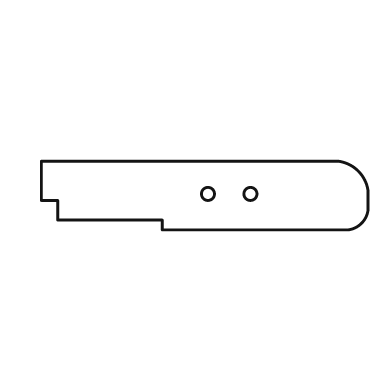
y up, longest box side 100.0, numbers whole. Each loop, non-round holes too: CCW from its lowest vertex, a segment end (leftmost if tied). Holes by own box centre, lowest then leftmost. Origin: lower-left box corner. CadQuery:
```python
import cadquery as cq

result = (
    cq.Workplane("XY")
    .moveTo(37.0, 0.0)
    .lineTo(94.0, 0.0)
    .threePointArc((98.0, 2.0), (100.0, 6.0))
    .lineTo(100.0, 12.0)
    .threePointArc((97.0, 18.0), (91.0, 21.0))
    .lineTo(0.0, 21.0)
    .lineTo(0.0, 9.0)
    .lineTo(5.0, 9.0)
    .lineTo(5.0, 3.0)
    .lineTo(37.0, 3.0)
    .close()
    .moveTo(51.0, 11.0)
    .circle(2.0)
    .moveTo(64.0, 11.0)
    .circle(2.0)
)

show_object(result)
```